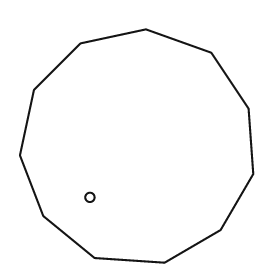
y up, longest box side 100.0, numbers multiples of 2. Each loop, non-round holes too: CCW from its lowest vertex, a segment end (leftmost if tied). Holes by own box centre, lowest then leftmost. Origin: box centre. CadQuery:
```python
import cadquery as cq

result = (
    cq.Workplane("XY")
    .moveTo(12.0, -50.0)
    .lineTo(36.0, -36.0)
    .lineTo(50.0, -12.0)
    .lineTo(48.0, 16.0)
    .lineTo(32.0, 40.0)
    .lineTo(4.0, 50.0)
    .lineTo(-24.0, 44.0)
    .lineTo(-44.0, 24.0)
    .lineTo(-50.0, -4.0)
    .lineTo(-40.0, -30.0)
    .lineTo(-18.0, -48.0)
    .close()
    .moveTo(-20.0, -22.0)
    .circle(2.0)
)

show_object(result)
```